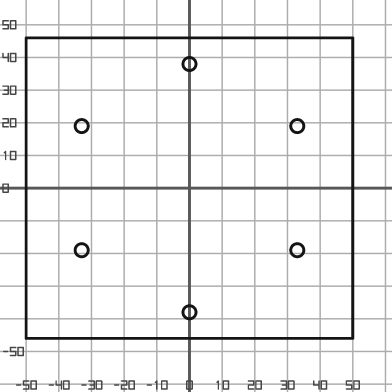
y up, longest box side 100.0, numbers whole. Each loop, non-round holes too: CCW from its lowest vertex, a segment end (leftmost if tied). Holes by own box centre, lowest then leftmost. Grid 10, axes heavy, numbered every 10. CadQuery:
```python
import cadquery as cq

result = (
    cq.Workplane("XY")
    .moveTo(-50.0, -46.0)
    .lineTo(50.0, -46.0)
    .lineTo(50.0, 46.0)
    .lineTo(-50.0, 46.0)
    .close()
    .moveTo(0.0, -38.0)
    .circle(2.0)
    .moveTo(-33.0, -19.0)
    .circle(2.0)
    .moveTo(33.0, -19.0)
    .circle(2.0)
    .moveTo(-33.0, 19.0)
    .circle(2.0)
    .moveTo(33.0, 19.0)
    .circle(2.0)
    .moveTo(0.0, 38.0)
    .circle(2.0)
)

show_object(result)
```